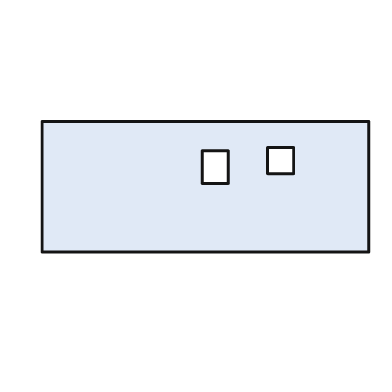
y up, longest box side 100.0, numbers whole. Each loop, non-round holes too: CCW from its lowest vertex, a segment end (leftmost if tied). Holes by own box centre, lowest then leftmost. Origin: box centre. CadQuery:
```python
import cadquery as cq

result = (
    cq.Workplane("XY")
    .moveTo(-50.0, -20.0)
    .lineTo(50.0, -20.0)
    .lineTo(50.0, 20.0)
    .lineTo(-50.0, 20.0)
    .close()
    .moveTo(-1.0, 1.0)
    .lineTo(7.0, 1.0)
    .lineTo(7.0, 11.0)
    .lineTo(-1.0, 11.0)
    .close()
    .moveTo(19.0, 4.0)
    .lineTo(27.0, 4.0)
    .lineTo(27.0, 12.0)
    .lineTo(19.0, 12.0)
    .close()
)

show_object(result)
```